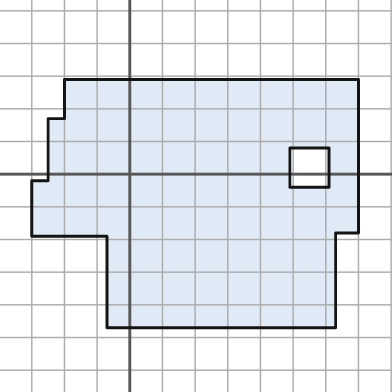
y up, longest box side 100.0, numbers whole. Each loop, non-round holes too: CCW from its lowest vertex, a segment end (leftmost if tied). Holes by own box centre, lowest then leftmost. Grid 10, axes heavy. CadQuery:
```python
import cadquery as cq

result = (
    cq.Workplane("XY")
    .moveTo(-7.0, -47.0)
    .lineTo(63.0, -47.0)
    .lineTo(63.0, -18.0)
    .lineTo(70.0, -18.0)
    .lineTo(70.0, 29.0)
    .lineTo(-20.0, 29.0)
    .lineTo(-20.0, 17.0)
    .lineTo(-25.0, 17.0)
    .lineTo(-25.0, -2.0)
    .lineTo(-30.0, -2.0)
    .lineTo(-30.0, -19.0)
    .lineTo(-7.0, -19.0)
    .close()
    .moveTo(49.0, -4.0)
    .lineTo(61.0, -4.0)
    .lineTo(61.0, 8.0)
    .lineTo(49.0, 8.0)
    .close()
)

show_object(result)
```